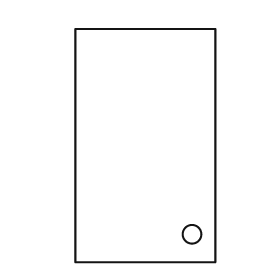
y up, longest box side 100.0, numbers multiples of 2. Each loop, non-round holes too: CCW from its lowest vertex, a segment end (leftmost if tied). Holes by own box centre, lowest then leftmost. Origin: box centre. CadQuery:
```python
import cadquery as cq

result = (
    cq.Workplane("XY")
    .moveTo(-30.0, -50.0)
    .lineTo(30.0, -50.0)
    .lineTo(30.0, 50.0)
    .lineTo(-30.0, 50.0)
    .close()
    .moveTo(20.0, -38.0)
    .circle(4.0)
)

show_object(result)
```